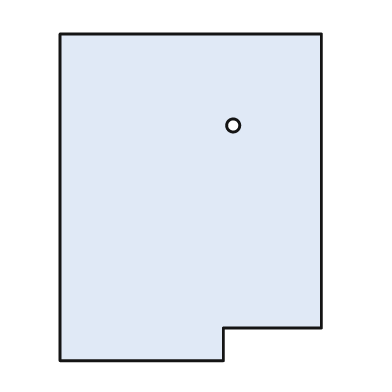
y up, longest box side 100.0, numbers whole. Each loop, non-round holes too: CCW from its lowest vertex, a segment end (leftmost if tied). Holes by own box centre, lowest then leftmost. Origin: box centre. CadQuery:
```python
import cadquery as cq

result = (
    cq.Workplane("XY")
    .moveTo(-40.0, -50.0)
    .lineTo(10.0, -50.0)
    .lineTo(10.0, -40.0)
    .lineTo(40.0, -40.0)
    .lineTo(40.0, 50.0)
    .lineTo(-40.0, 50.0)
    .close()
    .moveTo(13.0, 22.0)
    .circle(2.0)
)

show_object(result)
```